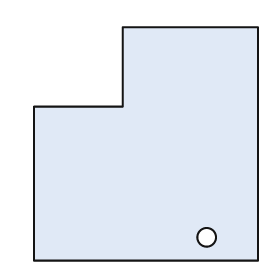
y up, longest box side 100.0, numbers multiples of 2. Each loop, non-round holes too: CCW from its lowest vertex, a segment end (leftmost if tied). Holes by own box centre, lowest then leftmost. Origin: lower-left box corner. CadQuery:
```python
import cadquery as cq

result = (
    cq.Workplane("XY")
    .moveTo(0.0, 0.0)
    .lineTo(96.0, 0.0)
    .lineTo(96.0, 100.0)
    .lineTo(38.0, 100.0)
    .lineTo(38.0, 66.0)
    .lineTo(0.0, 66.0)
    .close()
    .moveTo(74.0, 10.0)
    .circle(4.0)
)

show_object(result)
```